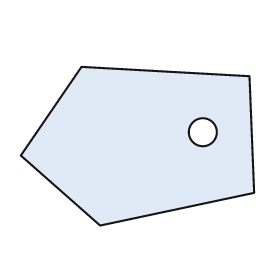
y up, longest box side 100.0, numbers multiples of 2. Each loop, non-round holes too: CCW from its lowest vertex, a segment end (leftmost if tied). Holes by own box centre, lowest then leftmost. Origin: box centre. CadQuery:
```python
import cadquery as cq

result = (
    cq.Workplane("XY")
    .moveTo(-16.0, -34.0)
    .lineTo(50.0, -20.0)
    .lineTo(48.0, 30.0)
    .lineTo(-24.0, 34.0)
    .lineTo(-50.0, -4.0)
    .close()
    .moveTo(28.0, 6.0)
    .circle(6.0)
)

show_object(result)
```